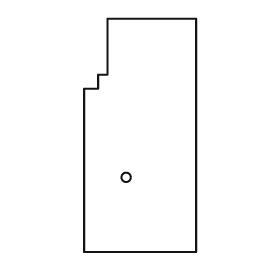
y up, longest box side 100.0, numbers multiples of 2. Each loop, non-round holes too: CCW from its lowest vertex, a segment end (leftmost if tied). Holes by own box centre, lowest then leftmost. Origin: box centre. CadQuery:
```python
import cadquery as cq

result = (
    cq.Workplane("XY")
    .moveTo(-24.0, -50.0)
    .lineTo(24.0, -50.0)
    .lineTo(24.0, 50.0)
    .lineTo(-14.0, 50.0)
    .lineTo(-14.0, 26.0)
    .lineTo(-18.0, 26.0)
    .lineTo(-18.0, 20.0)
    .lineTo(-24.0, 20.0)
    .close()
    .moveTo(-6.0, -18.0)
    .circle(2.0)
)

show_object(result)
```